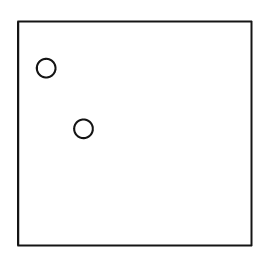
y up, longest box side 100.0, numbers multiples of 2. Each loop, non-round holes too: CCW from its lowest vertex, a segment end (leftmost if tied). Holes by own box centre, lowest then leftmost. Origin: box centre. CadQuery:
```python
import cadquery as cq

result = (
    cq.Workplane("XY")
    .moveTo(-50.0, -48.0)
    .lineTo(50.0, -48.0)
    .lineTo(50.0, 48.0)
    .lineTo(-50.0, 48.0)
    .close()
    .moveTo(-22.0, 2.0)
    .circle(4.0)
    .moveTo(-38.0, 28.0)
    .circle(4.0)
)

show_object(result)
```